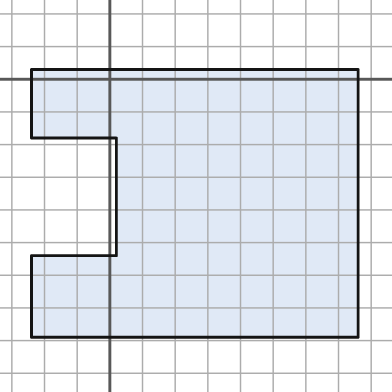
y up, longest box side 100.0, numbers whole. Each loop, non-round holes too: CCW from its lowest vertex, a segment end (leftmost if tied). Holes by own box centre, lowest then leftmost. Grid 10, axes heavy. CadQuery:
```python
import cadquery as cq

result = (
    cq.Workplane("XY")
    .moveTo(-24.0, -79.0)
    .lineTo(76.0, -79.0)
    .lineTo(76.0, 3.0)
    .lineTo(-24.0, 3.0)
    .lineTo(-24.0, -18.0)
    .lineTo(2.0, -18.0)
    .lineTo(2.0, -54.0)
    .lineTo(-24.0, -54.0)
    .close()
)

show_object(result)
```